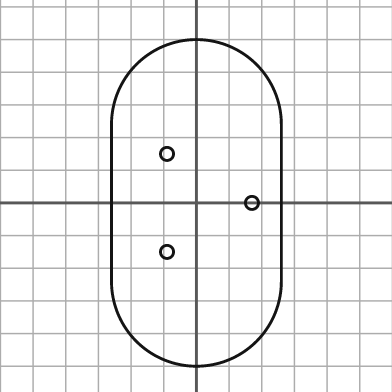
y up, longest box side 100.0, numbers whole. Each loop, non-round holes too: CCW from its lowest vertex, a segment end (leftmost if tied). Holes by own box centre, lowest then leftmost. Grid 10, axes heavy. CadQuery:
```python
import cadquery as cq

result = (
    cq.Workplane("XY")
    .moveTo(-26.0, -24.0)
    .threePointArc((0.0, -50.0), (26.0, -24.0))
    .lineTo(26.0, 24.0)
    .threePointArc((0.0, 50.0), (-26.0, 24.0))
    .close()
    .moveTo(-9.0, -15.0)
    .circle(2.0)
    .moveTo(17.0, 0.0)
    .circle(2.0)
    .moveTo(-9.0, 15.0)
    .circle(2.0)
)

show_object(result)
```